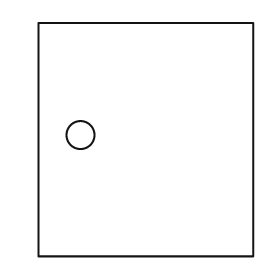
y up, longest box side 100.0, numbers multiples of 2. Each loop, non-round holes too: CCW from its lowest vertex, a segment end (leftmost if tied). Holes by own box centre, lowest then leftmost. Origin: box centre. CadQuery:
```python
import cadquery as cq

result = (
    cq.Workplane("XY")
    .moveTo(-46.0, -50.0)
    .lineTo(46.0, -50.0)
    .lineTo(46.0, 50.0)
    .lineTo(-46.0, 50.0)
    .close()
    .moveTo(-28.0, 2.0)
    .circle(6.0)
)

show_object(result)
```